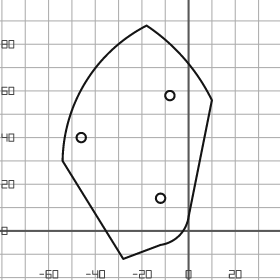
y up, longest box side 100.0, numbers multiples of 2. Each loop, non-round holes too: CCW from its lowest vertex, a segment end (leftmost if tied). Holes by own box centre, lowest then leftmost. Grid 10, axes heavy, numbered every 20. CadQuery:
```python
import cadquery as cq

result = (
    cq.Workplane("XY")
    .moveTo(-28.0, -12.0)
    .lineTo(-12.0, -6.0)
    .threePointArc((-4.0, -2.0), (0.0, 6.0))
    .lineTo(10.0, 56.0)
    .threePointArc((-2.0, 74.0), (-18.0, 88.0))
    .threePointArc((-44.0, 64.0), (-54.0, 30.0))
    .close()
    .moveTo(-12.0, 14.0)
    .circle(2.0)
    .moveTo(-46.0, 40.0)
    .circle(2.0)
    .moveTo(-8.0, 58.0)
    .circle(2.0)
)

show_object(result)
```